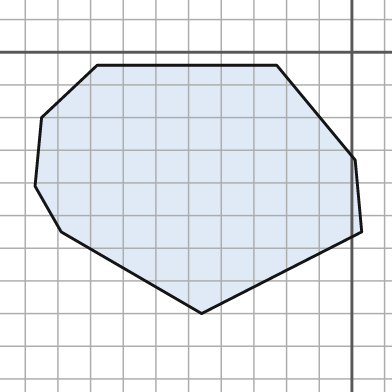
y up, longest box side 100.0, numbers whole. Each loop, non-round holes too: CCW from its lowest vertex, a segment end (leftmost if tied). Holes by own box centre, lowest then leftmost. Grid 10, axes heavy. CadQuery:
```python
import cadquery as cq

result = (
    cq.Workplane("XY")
    .moveTo(-46.0, -80.0)
    .lineTo(3.0, -55.0)
    .lineTo(1.0, -33.0)
    .lineTo(-23.0, -4.0)
    .lineTo(-78.0, -4.0)
    .lineTo(-95.0, -20.0)
    .lineTo(-97.0, -41.0)
    .lineTo(-89.0, -55.0)
    .close()
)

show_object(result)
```